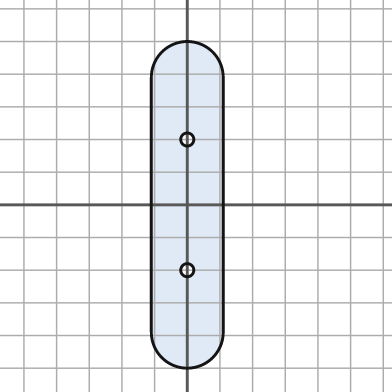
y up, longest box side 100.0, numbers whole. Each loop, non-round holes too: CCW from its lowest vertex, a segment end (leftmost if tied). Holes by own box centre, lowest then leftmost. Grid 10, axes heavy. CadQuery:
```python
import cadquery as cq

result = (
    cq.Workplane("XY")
    .moveTo(-11.0, -39.0)
    .threePointArc((0.0, -50.0), (11.0, -39.0))
    .lineTo(11.0, 39.0)
    .threePointArc((0.0, 50.0), (-11.0, 39.0))
    .close()
    .moveTo(0.0, -20.0)
    .circle(2.0)
    .moveTo(0.0, 20.0)
    .circle(2.0)
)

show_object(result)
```